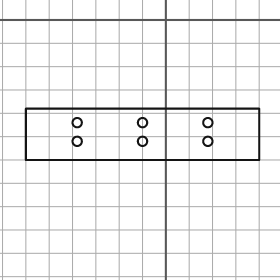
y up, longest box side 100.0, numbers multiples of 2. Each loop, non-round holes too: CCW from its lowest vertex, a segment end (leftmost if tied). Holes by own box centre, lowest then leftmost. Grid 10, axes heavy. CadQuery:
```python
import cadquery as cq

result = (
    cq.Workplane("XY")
    .moveTo(-60.0, -60.0)
    .lineTo(40.0, -60.0)
    .lineTo(40.0, -38.0)
    .lineTo(-60.0, -38.0)
    .close()
    .moveTo(-38.0, -52.0)
    .circle(2.0)
    .moveTo(-10.0, -52.0)
    .circle(2.0)
    .moveTo(18.0, -52.0)
    .circle(2.0)
    .moveTo(-38.0, -44.0)
    .circle(2.0)
    .moveTo(-10.0, -44.0)
    .circle(2.0)
    .moveTo(18.0, -44.0)
    .circle(2.0)
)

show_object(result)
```